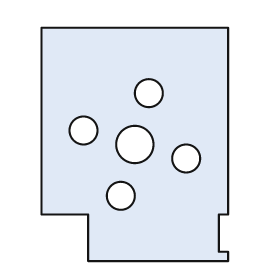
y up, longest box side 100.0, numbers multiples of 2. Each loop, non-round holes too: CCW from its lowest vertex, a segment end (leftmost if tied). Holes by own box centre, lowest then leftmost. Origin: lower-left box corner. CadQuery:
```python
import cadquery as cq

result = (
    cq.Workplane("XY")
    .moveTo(20.0, 0.0)
    .lineTo(80.0, 0.0)
    .lineTo(80.0, 4.0)
    .lineTo(76.0, 4.0)
    .lineTo(76.0, 20.0)
    .lineTo(80.0, 20.0)
    .lineTo(80.0, 100.0)
    .lineTo(0.0, 100.0)
    .lineTo(0.0, 20.0)
    .lineTo(20.0, 20.0)
    .close()
    .moveTo(34.0, 28.0)
    .circle(6.0)
    .moveTo(62.0, 44.0)
    .circle(6.0)
    .moveTo(40.0, 50.0)
    .circle(8.0)
    .moveTo(18.0, 56.0)
    .circle(6.0)
    .moveTo(46.0, 72.0)
    .circle(6.0)
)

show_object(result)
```